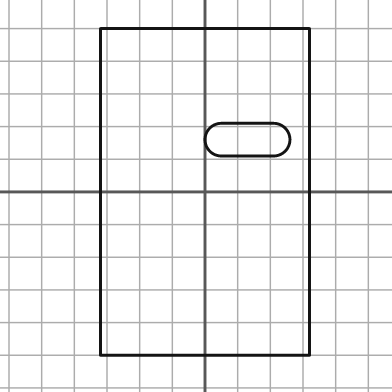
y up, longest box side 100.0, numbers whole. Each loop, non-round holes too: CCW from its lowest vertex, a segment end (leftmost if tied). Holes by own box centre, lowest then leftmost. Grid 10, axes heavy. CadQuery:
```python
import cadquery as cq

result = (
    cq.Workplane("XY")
    .moveTo(-32.0, -50.0)
    .lineTo(32.0, -50.0)
    .lineTo(32.0, 50.0)
    .lineTo(-32.0, 50.0)
    .close()
    .moveTo(5.0, 11.0)
    .lineTo(21.0, 11.0)
    .threePointArc((26.0, 16.0), (21.0, 21.0))
    .lineTo(5.0, 21.0)
    .threePointArc((0.0, 16.0), (5.0, 11.0))
    .close()
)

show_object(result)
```